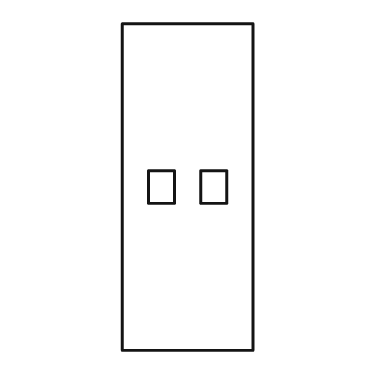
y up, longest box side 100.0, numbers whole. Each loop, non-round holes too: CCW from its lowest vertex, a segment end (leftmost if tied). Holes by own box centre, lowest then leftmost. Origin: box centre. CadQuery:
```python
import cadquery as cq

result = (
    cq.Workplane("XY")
    .moveTo(-20.0, -50.0)
    .lineTo(20.0, -50.0)
    .lineTo(20.0, 50.0)
    .lineTo(-20.0, 50.0)
    .close()
    .moveTo(-12.0, -5.0)
    .lineTo(-4.0, -5.0)
    .lineTo(-4.0, 5.0)
    .lineTo(-12.0, 5.0)
    .close()
    .moveTo(4.0, -5.0)
    .lineTo(12.0, -5.0)
    .lineTo(12.0, 5.0)
    .lineTo(4.0, 5.0)
    .close()
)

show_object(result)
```